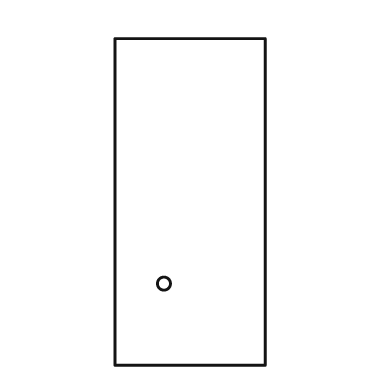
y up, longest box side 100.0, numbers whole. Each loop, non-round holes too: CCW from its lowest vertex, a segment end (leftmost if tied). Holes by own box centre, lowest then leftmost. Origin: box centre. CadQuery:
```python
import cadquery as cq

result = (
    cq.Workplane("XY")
    .moveTo(-23.0, -50.0)
    .lineTo(23.0, -50.0)
    .lineTo(23.0, 50.0)
    .lineTo(-23.0, 50.0)
    .close()
    .moveTo(-8.0, -25.0)
    .circle(2.0)
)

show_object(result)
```